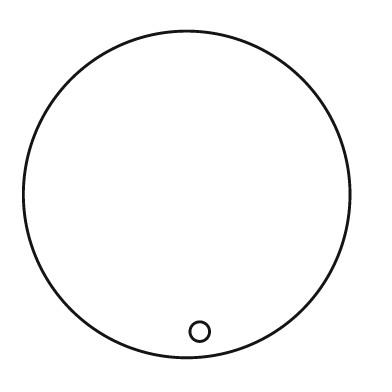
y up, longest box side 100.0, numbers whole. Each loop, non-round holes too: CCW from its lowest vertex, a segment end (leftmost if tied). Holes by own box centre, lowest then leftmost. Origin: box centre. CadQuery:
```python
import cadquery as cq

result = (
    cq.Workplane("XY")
    .moveTo(0.0, 0.0)
    .circle(50.0)
    .moveTo(4.0, -42.0)
    .circle(3.0)
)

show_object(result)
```